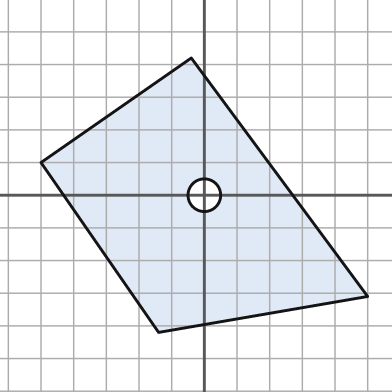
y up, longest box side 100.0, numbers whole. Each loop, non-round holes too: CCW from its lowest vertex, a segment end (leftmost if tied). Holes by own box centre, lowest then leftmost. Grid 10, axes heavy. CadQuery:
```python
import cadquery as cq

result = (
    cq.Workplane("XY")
    .moveTo(-14.0, -42.0)
    .lineTo(50.0, -31.0)
    .lineTo(-4.0, 42.0)
    .lineTo(-50.0, 10.0)
    .close()
    .moveTo(0.0, 0.0)
    .circle(5.0)
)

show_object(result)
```